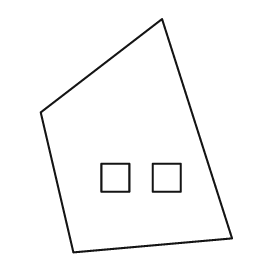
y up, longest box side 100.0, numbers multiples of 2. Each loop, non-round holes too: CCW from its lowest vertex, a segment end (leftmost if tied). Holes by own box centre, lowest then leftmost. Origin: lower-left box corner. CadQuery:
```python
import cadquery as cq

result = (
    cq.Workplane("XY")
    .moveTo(14.0, 0.0)
    .lineTo(82.0, 6.0)
    .lineTo(52.0, 100.0)
    .lineTo(0.0, 60.0)
    .close()
    .moveTo(26.0, 26.0)
    .lineTo(38.0, 26.0)
    .lineTo(38.0, 38.0)
    .lineTo(26.0, 38.0)
    .close()
    .moveTo(48.0, 26.0)
    .lineTo(60.0, 26.0)
    .lineTo(60.0, 38.0)
    .lineTo(48.0, 38.0)
    .close()
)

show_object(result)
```